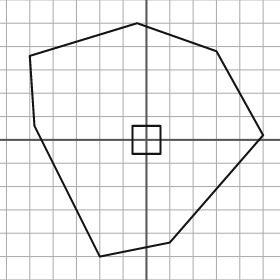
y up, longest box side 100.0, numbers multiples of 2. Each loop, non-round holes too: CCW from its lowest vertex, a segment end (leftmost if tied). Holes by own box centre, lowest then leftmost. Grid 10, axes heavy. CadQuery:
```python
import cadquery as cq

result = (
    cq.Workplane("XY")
    .moveTo(-20.0, -50.0)
    .lineTo(10.0, -44.0)
    .lineTo(50.0, 2.0)
    .lineTo(30.0, 38.0)
    .lineTo(-4.0, 50.0)
    .lineTo(-50.0, 36.0)
    .lineTo(-48.0, 6.0)
    .close()
    .moveTo(-6.0, -6.0)
    .lineTo(6.0, -6.0)
    .lineTo(6.0, 6.0)
    .lineTo(-6.0, 6.0)
    .close()
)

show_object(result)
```